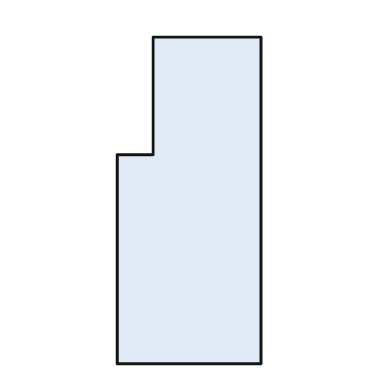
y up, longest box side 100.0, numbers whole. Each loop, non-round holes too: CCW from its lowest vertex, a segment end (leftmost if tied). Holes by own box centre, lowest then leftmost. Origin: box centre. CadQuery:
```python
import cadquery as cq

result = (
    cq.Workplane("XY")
    .moveTo(-22.0, -50.0)
    .lineTo(22.0, -50.0)
    .lineTo(22.0, 50.0)
    .lineTo(-11.0, 50.0)
    .lineTo(-11.0, 14.0)
    .lineTo(-22.0, 14.0)
    .close()
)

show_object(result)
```